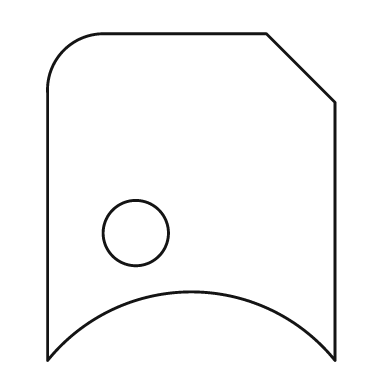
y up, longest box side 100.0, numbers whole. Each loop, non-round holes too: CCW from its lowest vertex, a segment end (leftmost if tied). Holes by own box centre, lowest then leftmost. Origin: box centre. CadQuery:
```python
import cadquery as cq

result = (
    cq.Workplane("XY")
    .moveTo(-44.0, -50.0)
    .threePointArc((0.0, -29.0), (44.0, -50.0))
    .lineTo(44.0, 29.0)
    .lineTo(23.0, 50.0)
    .lineTo(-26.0, 50.0)
    .threePointArc((-39.0, 45.0), (-44.0, 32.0))
    .close()
    .moveTo(-17.0, -11.0)
    .circle(10.0)
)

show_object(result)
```